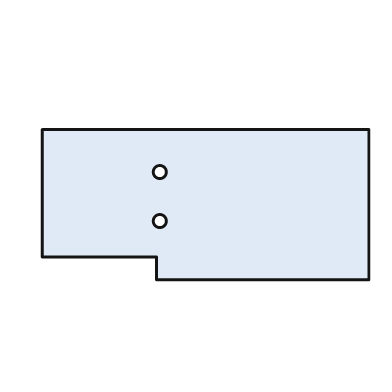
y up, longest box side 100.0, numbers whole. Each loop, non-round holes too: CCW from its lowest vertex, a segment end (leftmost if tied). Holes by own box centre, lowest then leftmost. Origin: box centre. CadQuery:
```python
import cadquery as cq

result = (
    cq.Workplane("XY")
    .moveTo(-15.0, -23.0)
    .lineTo(50.0, -23.0)
    .lineTo(50.0, 23.0)
    .lineTo(-50.0, 23.0)
    .lineTo(-50.0, -16.0)
    .lineTo(-15.0, -16.0)
    .close()
    .moveTo(-14.0, -5.0)
    .circle(2.0)
    .moveTo(-14.0, 10.0)
    .circle(2.0)
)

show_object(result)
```